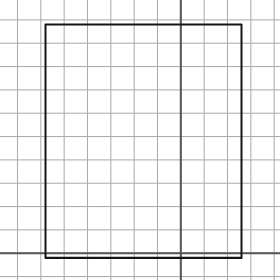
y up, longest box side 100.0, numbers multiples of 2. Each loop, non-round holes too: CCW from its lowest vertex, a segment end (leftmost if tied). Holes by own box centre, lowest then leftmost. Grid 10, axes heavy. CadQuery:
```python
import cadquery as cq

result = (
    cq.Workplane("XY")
    .moveTo(-58.0, -2.0)
    .lineTo(26.0, -2.0)
    .lineTo(26.0, 98.0)
    .lineTo(-58.0, 98.0)
    .close()
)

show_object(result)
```